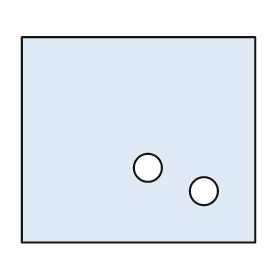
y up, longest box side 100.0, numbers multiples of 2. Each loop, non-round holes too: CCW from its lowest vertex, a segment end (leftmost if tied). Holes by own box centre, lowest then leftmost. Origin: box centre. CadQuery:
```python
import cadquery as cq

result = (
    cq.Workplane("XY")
    .moveTo(-50.0, -44.0)
    .lineTo(50.0, -44.0)
    .lineTo(50.0, 44.0)
    .lineTo(-50.0, 44.0)
    .close()
    .moveTo(28.0, -22.0)
    .circle(6.0)
    .moveTo(4.0, -12.0)
    .circle(6.0)
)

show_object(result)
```